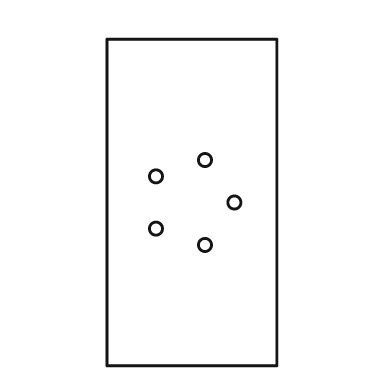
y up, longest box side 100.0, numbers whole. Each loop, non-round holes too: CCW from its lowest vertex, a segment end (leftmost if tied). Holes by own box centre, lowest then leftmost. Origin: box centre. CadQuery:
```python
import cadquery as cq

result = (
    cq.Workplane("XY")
    .moveTo(-26.0, -50.0)
    .lineTo(26.0, -50.0)
    .lineTo(26.0, 50.0)
    .lineTo(-26.0, 50.0)
    .close()
    .moveTo(4.0, -13.0)
    .circle(2.0)
    .moveTo(-11.0, -8.0)
    .circle(2.0)
    .moveTo(13.0, 0.0)
    .circle(2.0)
    .moveTo(-11.0, 8.0)
    .circle(2.0)
    .moveTo(4.0, 13.0)
    .circle(2.0)
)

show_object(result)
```